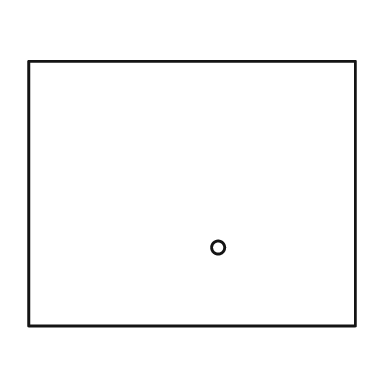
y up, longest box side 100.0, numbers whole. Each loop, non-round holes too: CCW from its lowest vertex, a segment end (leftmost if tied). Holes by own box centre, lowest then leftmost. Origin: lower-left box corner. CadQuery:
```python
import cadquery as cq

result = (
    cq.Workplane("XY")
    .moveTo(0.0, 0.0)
    .lineTo(100.0, 0.0)
    .lineTo(100.0, 81.0)
    .lineTo(0.0, 81.0)
    .close()
    .moveTo(58.0, 24.0)
    .circle(2.0)
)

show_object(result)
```